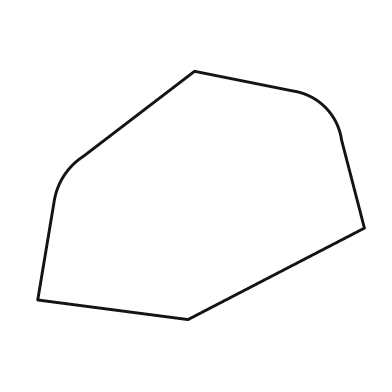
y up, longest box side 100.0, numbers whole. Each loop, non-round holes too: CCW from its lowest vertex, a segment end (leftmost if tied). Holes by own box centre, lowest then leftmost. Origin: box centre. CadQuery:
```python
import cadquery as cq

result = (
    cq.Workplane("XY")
    .moveTo(-4.0, -38.0)
    .lineTo(50.0, -10.0)
    .lineTo(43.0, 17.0)
    .threePointArc((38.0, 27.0), (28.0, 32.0))
    .lineTo(-2.0, 38.0)
    .lineTo(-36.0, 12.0)
    .threePointArc((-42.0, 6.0), (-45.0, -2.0))
    .lineTo(-50.0, -32.0)
    .close()
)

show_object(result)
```